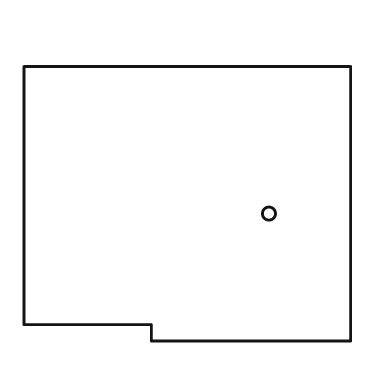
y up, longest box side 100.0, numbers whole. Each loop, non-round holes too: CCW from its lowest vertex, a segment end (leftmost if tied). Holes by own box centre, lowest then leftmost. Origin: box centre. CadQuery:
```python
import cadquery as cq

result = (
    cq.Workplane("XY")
    .moveTo(-11.0, -42.0)
    .lineTo(50.0, -42.0)
    .lineTo(50.0, 42.0)
    .lineTo(-50.0, 42.0)
    .lineTo(-50.0, -37.0)
    .lineTo(-11.0, -37.0)
    .close()
    .moveTo(25.0, -3.0)
    .circle(2.0)
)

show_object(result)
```